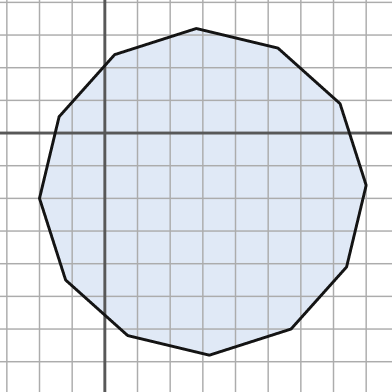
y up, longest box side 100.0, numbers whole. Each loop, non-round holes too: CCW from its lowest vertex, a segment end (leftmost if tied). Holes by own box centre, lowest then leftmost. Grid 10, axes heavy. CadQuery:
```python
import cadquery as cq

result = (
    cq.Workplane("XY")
    .moveTo(32.0, -68.0)
    .lineTo(57.0, -60.0)
    .lineTo(74.0, -41.0)
    .lineTo(80.0, -16.0)
    .lineTo(72.0, 9.0)
    .lineTo(53.0, 26.0)
    .lineTo(28.0, 32.0)
    .lineTo(3.0, 24.0)
    .lineTo(-14.0, 5.0)
    .lineTo(-20.0, -20.0)
    .lineTo(-12.0, -45.0)
    .lineTo(7.0, -62.0)
    .close()
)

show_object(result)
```